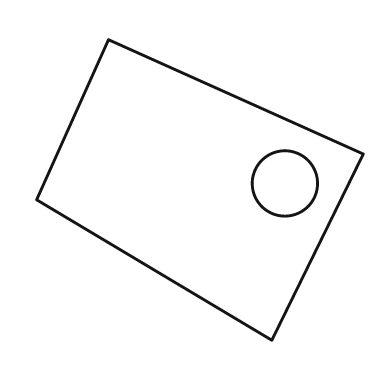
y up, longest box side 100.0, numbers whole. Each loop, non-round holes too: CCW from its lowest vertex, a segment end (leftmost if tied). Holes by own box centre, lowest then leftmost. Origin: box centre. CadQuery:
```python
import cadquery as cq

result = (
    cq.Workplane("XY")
    .moveTo(22.0, -46.0)
    .lineTo(50.0, 11.0)
    .lineTo(-28.0, 46.0)
    .lineTo(-50.0, -3.0)
    .close()
    .moveTo(26.0, 2.0)
    .circle(10.0)
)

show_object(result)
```